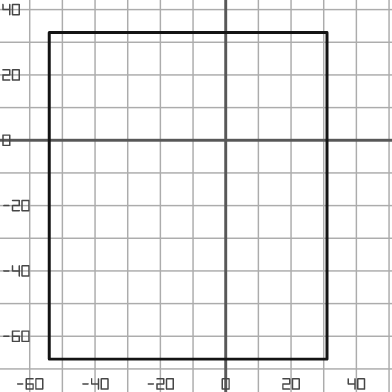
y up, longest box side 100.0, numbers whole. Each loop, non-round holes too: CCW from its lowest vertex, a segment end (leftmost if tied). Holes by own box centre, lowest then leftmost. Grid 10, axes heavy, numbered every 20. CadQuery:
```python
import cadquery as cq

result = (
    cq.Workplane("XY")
    .moveTo(-54.0, -67.0)
    .lineTo(31.0, -67.0)
    .lineTo(31.0, 33.0)
    .lineTo(-54.0, 33.0)
    .close()
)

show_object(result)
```